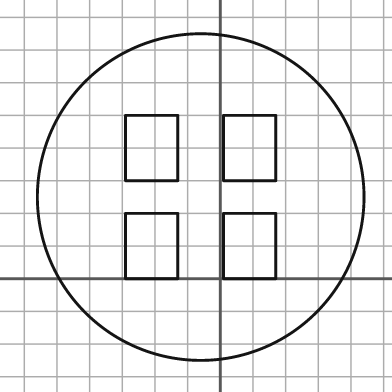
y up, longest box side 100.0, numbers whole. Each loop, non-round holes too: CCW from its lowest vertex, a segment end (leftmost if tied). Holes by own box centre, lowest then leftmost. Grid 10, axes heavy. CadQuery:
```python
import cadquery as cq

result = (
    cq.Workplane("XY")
    .moveTo(-6.0, 25.0)
    .circle(50.0)
    .moveTo(-29.0, 0.0)
    .lineTo(-13.0, 0.0)
    .lineTo(-13.0, 20.0)
    .lineTo(-29.0, 20.0)
    .close()
    .moveTo(1.0, 0.0)
    .lineTo(17.0, 0.0)
    .lineTo(17.0, 20.0)
    .lineTo(1.0, 20.0)
    .close()
    .moveTo(-29.0, 30.0)
    .lineTo(-13.0, 30.0)
    .lineTo(-13.0, 50.0)
    .lineTo(-29.0, 50.0)
    .close()
    .moveTo(1.0, 30.0)
    .lineTo(17.0, 30.0)
    .lineTo(17.0, 50.0)
    .lineTo(1.0, 50.0)
    .close()
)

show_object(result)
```